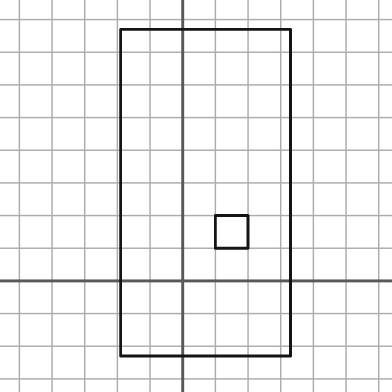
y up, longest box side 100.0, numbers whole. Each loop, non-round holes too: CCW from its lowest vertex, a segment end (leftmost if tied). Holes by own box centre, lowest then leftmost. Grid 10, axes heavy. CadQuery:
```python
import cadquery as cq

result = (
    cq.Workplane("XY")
    .moveTo(-19.0, -23.0)
    .lineTo(33.0, -23.0)
    .lineTo(33.0, 77.0)
    .lineTo(-19.0, 77.0)
    .close()
    .moveTo(10.0, 10.0)
    .lineTo(20.0, 10.0)
    .lineTo(20.0, 20.0)
    .lineTo(10.0, 20.0)
    .close()
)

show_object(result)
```